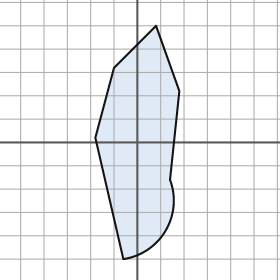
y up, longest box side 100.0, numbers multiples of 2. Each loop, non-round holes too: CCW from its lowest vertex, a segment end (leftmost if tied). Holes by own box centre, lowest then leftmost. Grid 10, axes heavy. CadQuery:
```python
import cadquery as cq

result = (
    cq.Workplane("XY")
    .moveTo(-6.0, -50.0)
    .threePointArc((12.0, -38.0), (14.0, -16.0))
    .lineTo(18.0, 22.0)
    .lineTo(8.0, 50.0)
    .lineTo(-10.0, 32.0)
    .lineTo(-18.0, 2.0)
    .close()
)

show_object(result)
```